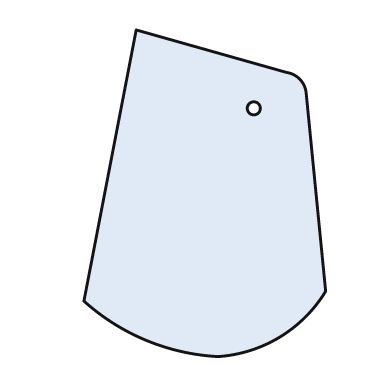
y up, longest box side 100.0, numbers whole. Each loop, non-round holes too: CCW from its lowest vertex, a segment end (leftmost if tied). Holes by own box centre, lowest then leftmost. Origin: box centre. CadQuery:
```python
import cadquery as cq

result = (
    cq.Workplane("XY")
    .moveTo(4.0, -50.0)
    .threePointArc((23.0, -44.0), (37.0, -30.0))
    .lineTo(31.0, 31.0)
    .threePointArc((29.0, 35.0), (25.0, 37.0))
    .lineTo(-21.0, 50.0)
    .lineTo(-37.0, -33.0)
    .threePointArc((-18.0, -45.0), (4.0, -50.0))
    .close()
    .moveTo(15.0, 26.0)
    .circle(2.0)
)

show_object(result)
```